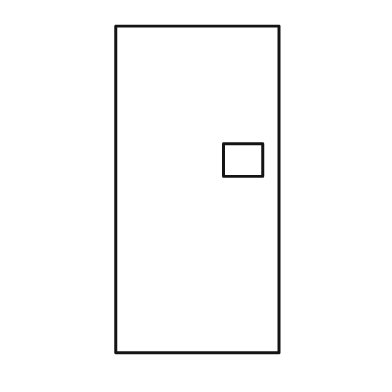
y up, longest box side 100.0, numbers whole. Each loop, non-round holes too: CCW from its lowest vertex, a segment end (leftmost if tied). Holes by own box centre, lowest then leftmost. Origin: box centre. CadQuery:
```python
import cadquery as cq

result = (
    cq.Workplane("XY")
    .moveTo(-25.0, -50.0)
    .lineTo(25.0, -50.0)
    .lineTo(25.0, 50.0)
    .lineTo(-25.0, 50.0)
    .close()
    .moveTo(8.0, 4.0)
    .lineTo(20.0, 4.0)
    .lineTo(20.0, 14.0)
    .lineTo(8.0, 14.0)
    .close()
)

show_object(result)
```